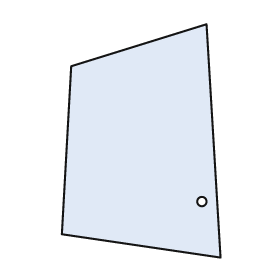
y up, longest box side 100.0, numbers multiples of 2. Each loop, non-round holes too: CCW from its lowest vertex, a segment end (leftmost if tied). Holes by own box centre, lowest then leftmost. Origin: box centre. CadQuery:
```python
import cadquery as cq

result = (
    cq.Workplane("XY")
    .moveTo(34.0, -50.0)
    .lineTo(28.0, 50.0)
    .lineTo(-30.0, 32.0)
    .lineTo(-34.0, -40.0)
    .close()
    .moveTo(26.0, -26.0)
    .circle(2.0)
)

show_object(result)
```